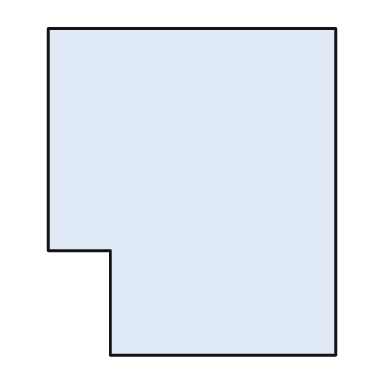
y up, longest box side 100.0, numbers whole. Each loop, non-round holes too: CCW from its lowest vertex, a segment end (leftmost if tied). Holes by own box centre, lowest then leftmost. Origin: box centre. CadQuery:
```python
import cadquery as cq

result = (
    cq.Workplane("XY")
    .moveTo(-25.0, -50.0)
    .lineTo(44.0, -50.0)
    .lineTo(44.0, 50.0)
    .lineTo(-44.0, 50.0)
    .lineTo(-44.0, -18.0)
    .lineTo(-25.0, -18.0)
    .close()
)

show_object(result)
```